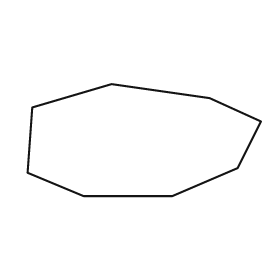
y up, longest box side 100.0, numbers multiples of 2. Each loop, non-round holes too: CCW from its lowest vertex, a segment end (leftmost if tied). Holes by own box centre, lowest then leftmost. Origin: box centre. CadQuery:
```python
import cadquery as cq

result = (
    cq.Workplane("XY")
    .moveTo(-26.0, -24.0)
    .lineTo(12.0, -24.0)
    .lineTo(40.0, -12.0)
    .lineTo(50.0, 8.0)
    .lineTo(28.0, 18.0)
    .lineTo(-14.0, 24.0)
    .lineTo(-48.0, 14.0)
    .lineTo(-50.0, -14.0)
    .close()
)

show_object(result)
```